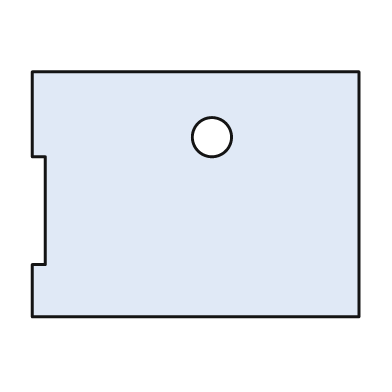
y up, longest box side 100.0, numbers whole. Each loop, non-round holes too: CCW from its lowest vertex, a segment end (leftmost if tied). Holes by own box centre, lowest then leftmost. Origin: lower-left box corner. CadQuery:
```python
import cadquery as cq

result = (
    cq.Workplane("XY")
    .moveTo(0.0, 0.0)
    .lineTo(100.0, 0.0)
    .lineTo(100.0, 75.0)
    .lineTo(0.0, 75.0)
    .lineTo(0.0, 49.0)
    .lineTo(4.0, 49.0)
    .lineTo(4.0, 16.0)
    .lineTo(0.0, 16.0)
    .close()
    .moveTo(55.0, 55.0)
    .circle(6.0)
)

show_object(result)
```